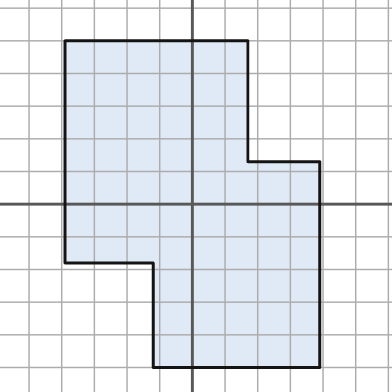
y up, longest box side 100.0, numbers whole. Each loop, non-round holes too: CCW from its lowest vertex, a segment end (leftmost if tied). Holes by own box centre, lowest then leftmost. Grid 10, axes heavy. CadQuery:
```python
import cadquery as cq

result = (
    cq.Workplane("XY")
    .moveTo(-12.0, -50.0)
    .lineTo(39.0, -50.0)
    .lineTo(39.0, 13.0)
    .lineTo(17.0, 13.0)
    .lineTo(17.0, 50.0)
    .lineTo(-39.0, 50.0)
    .lineTo(-39.0, -18.0)
    .lineTo(-12.0, -18.0)
    .close()
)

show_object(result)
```